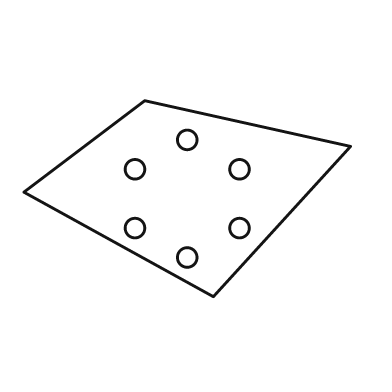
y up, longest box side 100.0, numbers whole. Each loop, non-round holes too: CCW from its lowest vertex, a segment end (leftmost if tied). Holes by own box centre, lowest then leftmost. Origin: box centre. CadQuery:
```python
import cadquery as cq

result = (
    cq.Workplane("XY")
    .moveTo(8.0, -30.0)
    .lineTo(50.0, 16.0)
    .lineTo(-13.0, 30.0)
    .lineTo(-50.0, 2.0)
    .close()
    .moveTo(0.0, -18.0)
    .circle(3.0)
    .moveTo(-16.0, -9.0)
    .circle(3.0)
    .moveTo(16.0, -9.0)
    .circle(3.0)
    .moveTo(-16.0, 9.0)
    .circle(3.0)
    .moveTo(16.0, 9.0)
    .circle(3.0)
    .moveTo(0.0, 18.0)
    .circle(3.0)
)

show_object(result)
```